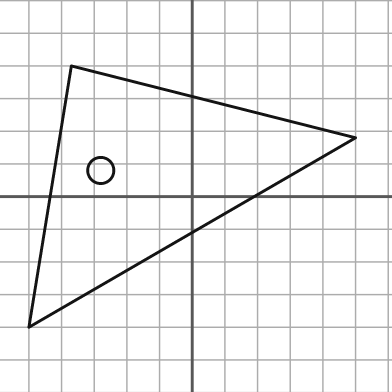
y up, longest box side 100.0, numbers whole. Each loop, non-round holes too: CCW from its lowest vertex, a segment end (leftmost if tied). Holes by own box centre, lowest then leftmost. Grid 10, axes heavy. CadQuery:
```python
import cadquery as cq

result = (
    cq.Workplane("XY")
    .moveTo(-50.0, -40.0)
    .lineTo(50.0, 18.0)
    .lineTo(-37.0, 40.0)
    .close()
    .moveTo(-28.0, 8.0)
    .circle(4.0)
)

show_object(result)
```